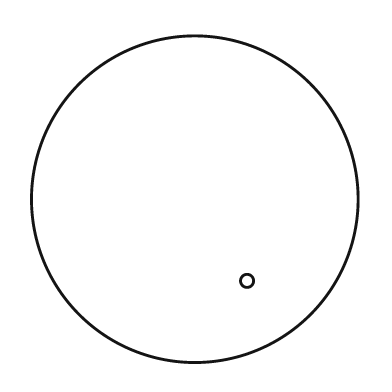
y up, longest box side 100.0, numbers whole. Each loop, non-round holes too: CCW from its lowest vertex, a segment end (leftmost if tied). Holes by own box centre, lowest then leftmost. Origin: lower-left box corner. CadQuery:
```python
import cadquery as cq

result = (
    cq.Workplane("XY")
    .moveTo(50.0, 50.0)
    .circle(50.0)
    .moveTo(66.0, 25.0)
    .circle(2.0)
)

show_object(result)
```